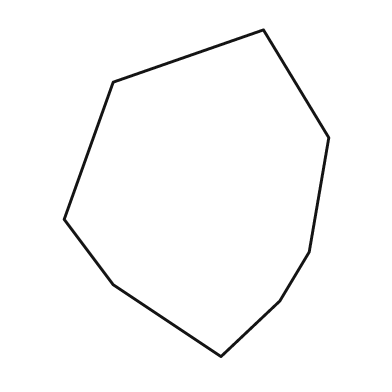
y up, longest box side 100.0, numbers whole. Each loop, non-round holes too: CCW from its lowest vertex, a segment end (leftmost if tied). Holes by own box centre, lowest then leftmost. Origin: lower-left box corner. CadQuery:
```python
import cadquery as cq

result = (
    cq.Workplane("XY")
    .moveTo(48.0, 0.0)
    .lineTo(66.0, 17.0)
    .lineTo(75.0, 32.0)
    .lineTo(81.0, 67.0)
    .lineTo(61.0, 100.0)
    .lineTo(15.0, 84.0)
    .lineTo(0.0, 42.0)
    .lineTo(15.0, 22.0)
    .close()
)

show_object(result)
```